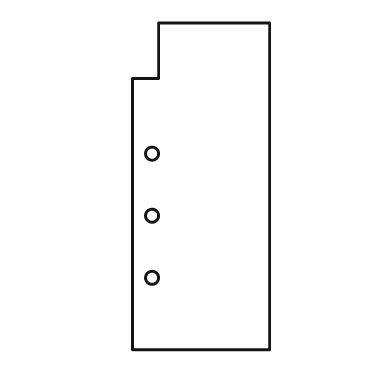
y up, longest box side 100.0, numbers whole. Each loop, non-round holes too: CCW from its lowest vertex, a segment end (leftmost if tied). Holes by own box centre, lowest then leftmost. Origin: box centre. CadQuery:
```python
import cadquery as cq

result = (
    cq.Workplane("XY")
    .moveTo(-21.0, -50.0)
    .lineTo(21.0, -50.0)
    .lineTo(21.0, 50.0)
    .lineTo(-13.0, 50.0)
    .lineTo(-13.0, 33.0)
    .lineTo(-21.0, 33.0)
    .close()
    .moveTo(-15.0, -28.0)
    .circle(2.0)
    .moveTo(-15.0, -9.0)
    .circle(2.0)
    .moveTo(-15.0, 10.0)
    .circle(2.0)
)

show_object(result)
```